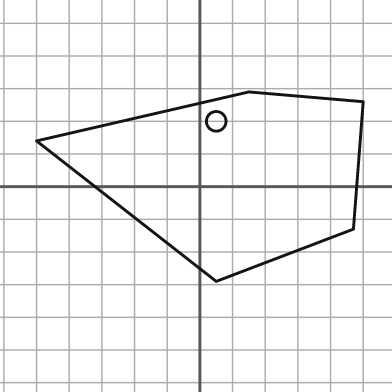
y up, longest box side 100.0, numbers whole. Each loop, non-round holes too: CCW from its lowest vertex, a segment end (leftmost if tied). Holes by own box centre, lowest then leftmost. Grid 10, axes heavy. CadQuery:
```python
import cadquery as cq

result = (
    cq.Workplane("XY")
    .moveTo(5.0, -29.0)
    .lineTo(47.0, -13.0)
    .lineTo(50.0, 26.0)
    .lineTo(15.0, 29.0)
    .lineTo(-50.0, 14.0)
    .close()
    .moveTo(5.0, 20.0)
    .circle(3.0)
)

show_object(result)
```